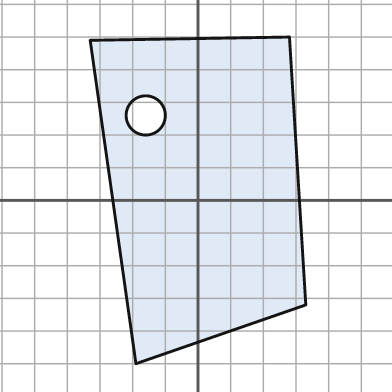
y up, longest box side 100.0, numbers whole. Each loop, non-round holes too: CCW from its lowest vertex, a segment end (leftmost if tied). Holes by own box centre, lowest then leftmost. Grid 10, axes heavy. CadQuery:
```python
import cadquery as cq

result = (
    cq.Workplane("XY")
    .moveTo(-19.0, -50.0)
    .lineTo(33.0, -32.0)
    .lineTo(28.0, 50.0)
    .lineTo(-33.0, 49.0)
    .close()
    .moveTo(-16.0, 26.0)
    .circle(6.0)
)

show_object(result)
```